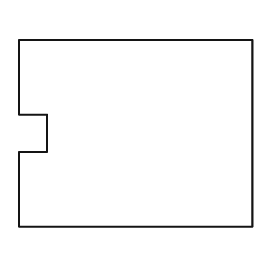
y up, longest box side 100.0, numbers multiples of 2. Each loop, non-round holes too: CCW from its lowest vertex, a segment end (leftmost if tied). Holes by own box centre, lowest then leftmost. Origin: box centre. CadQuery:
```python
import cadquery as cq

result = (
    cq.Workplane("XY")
    .moveTo(-50.0, -40.0)
    .lineTo(50.0, -40.0)
    .lineTo(50.0, 40.0)
    .lineTo(-50.0, 40.0)
    .lineTo(-50.0, 8.0)
    .lineTo(-38.0, 8.0)
    .lineTo(-38.0, -8.0)
    .lineTo(-50.0, -8.0)
    .close()
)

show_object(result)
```